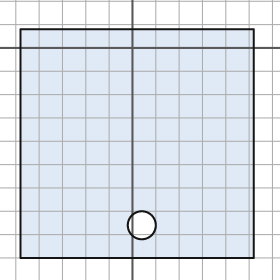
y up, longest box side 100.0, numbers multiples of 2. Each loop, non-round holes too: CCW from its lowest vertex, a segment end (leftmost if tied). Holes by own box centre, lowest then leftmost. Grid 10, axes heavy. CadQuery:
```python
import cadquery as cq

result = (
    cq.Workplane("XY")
    .moveTo(-48.0, -90.0)
    .lineTo(52.0, -90.0)
    .lineTo(52.0, 8.0)
    .lineTo(-48.0, 8.0)
    .close()
    .moveTo(4.0, -76.0)
    .circle(6.0)
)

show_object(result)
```